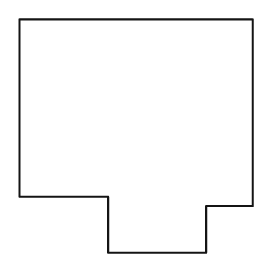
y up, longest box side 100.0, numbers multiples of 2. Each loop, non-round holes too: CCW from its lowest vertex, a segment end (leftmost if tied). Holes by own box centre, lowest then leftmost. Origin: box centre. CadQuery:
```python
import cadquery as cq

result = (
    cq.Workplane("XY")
    .moveTo(-12.0, -50.0)
    .lineTo(30.0, -50.0)
    .lineTo(30.0, -30.0)
    .lineTo(50.0, -30.0)
    .lineTo(50.0, 50.0)
    .lineTo(-50.0, 50.0)
    .lineTo(-50.0, -26.0)
    .lineTo(-12.0, -26.0)
    .close()
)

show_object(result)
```